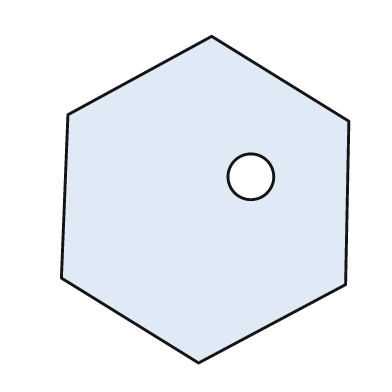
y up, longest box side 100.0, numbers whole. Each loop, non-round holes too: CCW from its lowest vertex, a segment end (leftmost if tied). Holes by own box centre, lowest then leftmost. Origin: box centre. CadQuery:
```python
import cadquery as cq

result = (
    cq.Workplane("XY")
    .moveTo(-2.0, -50.0)
    .lineTo(43.0, -26.0)
    .lineTo(44.0, 24.0)
    .lineTo(2.0, 50.0)
    .lineTo(-42.0, 26.0)
    .lineTo(-44.0, -24.0)
    .close()
    .moveTo(14.0, 7.0)
    .circle(7.0)
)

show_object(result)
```